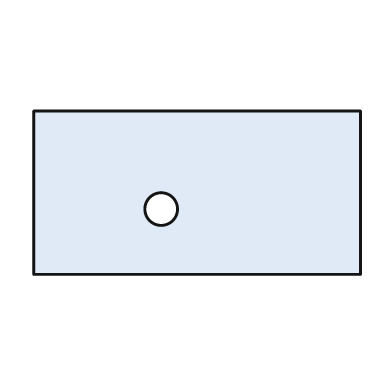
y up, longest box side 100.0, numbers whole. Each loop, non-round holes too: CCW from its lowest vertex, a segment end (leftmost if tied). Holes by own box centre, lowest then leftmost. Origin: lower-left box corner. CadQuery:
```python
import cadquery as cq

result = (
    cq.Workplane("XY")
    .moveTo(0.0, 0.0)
    .lineTo(100.0, 0.0)
    .lineTo(100.0, 50.0)
    .lineTo(0.0, 50.0)
    .close()
    .moveTo(39.0, 20.0)
    .circle(5.0)
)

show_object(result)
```